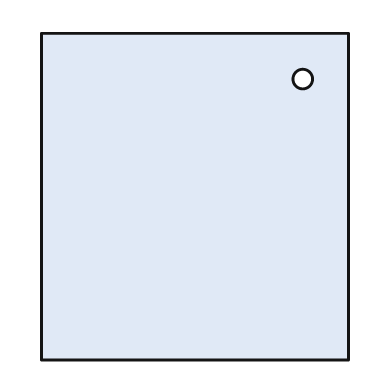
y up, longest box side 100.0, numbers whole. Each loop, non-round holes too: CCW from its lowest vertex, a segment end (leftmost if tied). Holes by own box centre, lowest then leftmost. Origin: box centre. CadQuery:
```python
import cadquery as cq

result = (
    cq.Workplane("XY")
    .moveTo(-47.0, -50.0)
    .lineTo(47.0, -50.0)
    .lineTo(47.0, 50.0)
    .lineTo(-47.0, 50.0)
    .close()
    .moveTo(33.0, 36.0)
    .circle(3.0)
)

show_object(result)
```